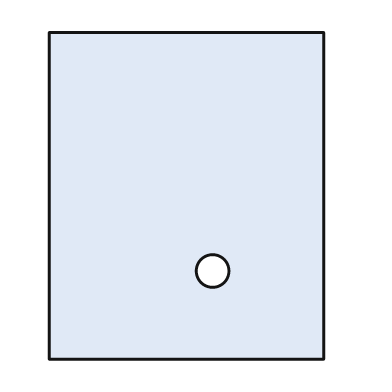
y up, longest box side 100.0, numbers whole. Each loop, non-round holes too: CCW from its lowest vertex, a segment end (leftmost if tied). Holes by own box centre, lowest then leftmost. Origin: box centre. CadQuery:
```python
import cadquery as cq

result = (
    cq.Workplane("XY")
    .moveTo(-42.0, -50.0)
    .lineTo(42.0, -50.0)
    .lineTo(42.0, 50.0)
    .lineTo(-42.0, 50.0)
    .close()
    .moveTo(8.0, -23.0)
    .circle(5.0)
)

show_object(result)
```